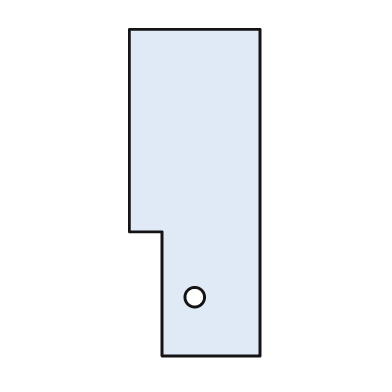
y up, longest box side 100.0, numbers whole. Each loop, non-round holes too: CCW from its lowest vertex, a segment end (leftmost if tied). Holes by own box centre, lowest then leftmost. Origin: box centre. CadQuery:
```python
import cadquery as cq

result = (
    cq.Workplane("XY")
    .moveTo(-10.0, -50.0)
    .lineTo(20.0, -50.0)
    .lineTo(20.0, 50.0)
    .lineTo(-20.0, 50.0)
    .lineTo(-20.0, -12.0)
    .lineTo(-10.0, -12.0)
    .close()
    .moveTo(0.0, -32.0)
    .circle(3.0)
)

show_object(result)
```